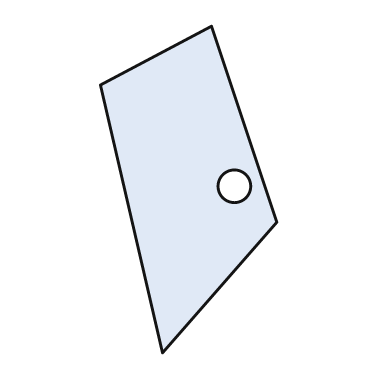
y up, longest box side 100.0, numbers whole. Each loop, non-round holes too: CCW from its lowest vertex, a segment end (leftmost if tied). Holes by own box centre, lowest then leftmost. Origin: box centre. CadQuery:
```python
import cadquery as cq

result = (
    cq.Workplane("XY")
    .moveTo(-8.0, -50.0)
    .lineTo(27.0, -10.0)
    .lineTo(7.0, 50.0)
    .lineTo(-27.0, 32.0)
    .close()
    .moveTo(14.0, 1.0)
    .circle(5.0)
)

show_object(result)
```